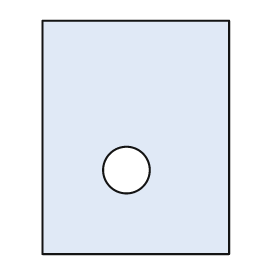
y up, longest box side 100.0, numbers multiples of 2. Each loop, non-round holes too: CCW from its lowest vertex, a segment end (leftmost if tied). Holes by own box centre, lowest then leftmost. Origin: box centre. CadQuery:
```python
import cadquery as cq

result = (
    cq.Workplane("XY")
    .moveTo(-40.0, -50.0)
    .lineTo(40.0, -50.0)
    .lineTo(40.0, 50.0)
    .lineTo(-40.0, 50.0)
    .close()
    .moveTo(-4.0, -14.0)
    .circle(10.0)
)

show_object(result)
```